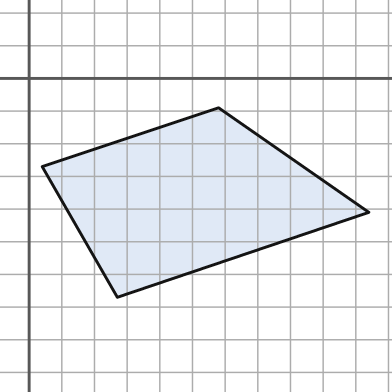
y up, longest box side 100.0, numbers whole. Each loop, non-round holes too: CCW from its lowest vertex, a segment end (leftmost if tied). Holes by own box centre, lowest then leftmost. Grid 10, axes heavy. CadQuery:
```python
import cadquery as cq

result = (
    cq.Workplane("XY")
    .moveTo(27.0, -67.0)
    .lineTo(104.0, -41.0)
    .lineTo(58.0, -9.0)
    .lineTo(4.0, -27.0)
    .close()
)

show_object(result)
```